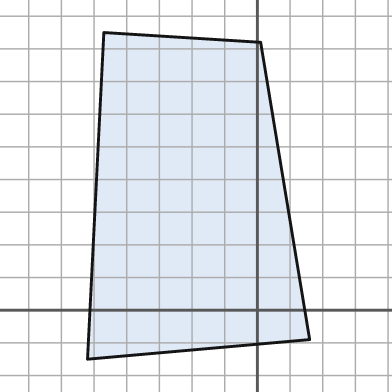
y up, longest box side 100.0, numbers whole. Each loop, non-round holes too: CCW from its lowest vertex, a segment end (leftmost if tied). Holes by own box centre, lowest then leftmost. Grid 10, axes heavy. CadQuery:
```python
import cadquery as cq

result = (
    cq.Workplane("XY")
    .moveTo(-52.0, -15.0)
    .lineTo(16.0, -9.0)
    .lineTo(1.0, 82.0)
    .lineTo(-47.0, 85.0)
    .close()
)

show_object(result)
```